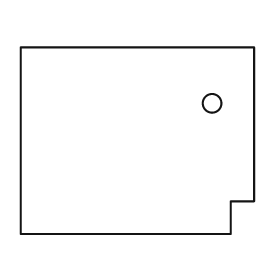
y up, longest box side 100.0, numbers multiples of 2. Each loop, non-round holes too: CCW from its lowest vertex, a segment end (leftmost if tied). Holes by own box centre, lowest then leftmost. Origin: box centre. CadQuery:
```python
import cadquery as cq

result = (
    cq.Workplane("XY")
    .moveTo(-50.0, -40.0)
    .lineTo(40.0, -40.0)
    .lineTo(40.0, -26.0)
    .lineTo(50.0, -26.0)
    .lineTo(50.0, 40.0)
    .lineTo(-50.0, 40.0)
    .close()
    .moveTo(32.0, 16.0)
    .circle(4.0)
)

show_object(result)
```